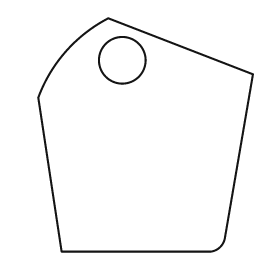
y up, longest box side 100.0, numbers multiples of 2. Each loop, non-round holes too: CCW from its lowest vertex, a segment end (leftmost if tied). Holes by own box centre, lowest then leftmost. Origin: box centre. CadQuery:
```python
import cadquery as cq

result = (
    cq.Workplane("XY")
    .moveTo(-36.0, -50.0)
    .lineTo(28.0, -50.0)
    .threePointArc((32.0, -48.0), (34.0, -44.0))
    .lineTo(46.0, 26.0)
    .lineTo(-16.0, 50.0)
    .threePointArc((-34.0, 36.0), (-46.0, 16.0))
    .close()
    .moveTo(-10.0, 32.0)
    .circle(10.0)
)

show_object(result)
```